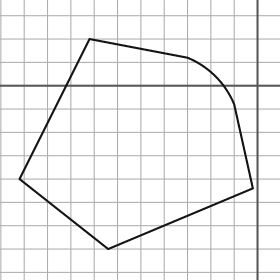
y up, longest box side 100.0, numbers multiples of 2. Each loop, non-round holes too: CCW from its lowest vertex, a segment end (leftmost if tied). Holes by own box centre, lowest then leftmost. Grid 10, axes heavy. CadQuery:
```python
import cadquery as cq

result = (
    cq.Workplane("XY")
    .moveTo(-64.0, -70.0)
    .lineTo(-2.0, -44.0)
    .lineTo(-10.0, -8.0)
    .threePointArc((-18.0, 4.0), (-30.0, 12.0))
    .lineTo(-72.0, 20.0)
    .lineTo(-102.0, -40.0)
    .close()
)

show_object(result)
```